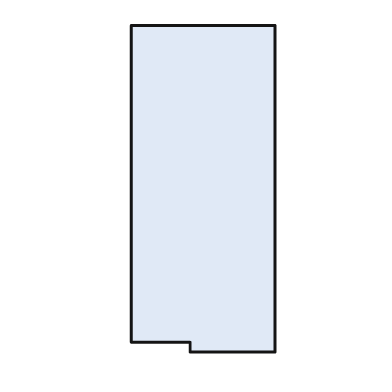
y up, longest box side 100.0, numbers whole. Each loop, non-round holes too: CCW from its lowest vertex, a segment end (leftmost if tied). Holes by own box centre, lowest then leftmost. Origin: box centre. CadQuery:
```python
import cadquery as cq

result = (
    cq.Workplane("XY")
    .moveTo(-4.0, -50.0)
    .lineTo(22.0, -50.0)
    .lineTo(22.0, 50.0)
    .lineTo(-22.0, 50.0)
    .lineTo(-22.0, -47.0)
    .lineTo(-4.0, -47.0)
    .close()
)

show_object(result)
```